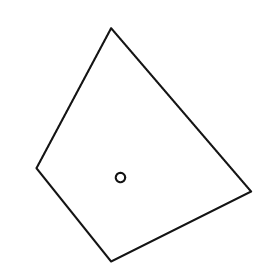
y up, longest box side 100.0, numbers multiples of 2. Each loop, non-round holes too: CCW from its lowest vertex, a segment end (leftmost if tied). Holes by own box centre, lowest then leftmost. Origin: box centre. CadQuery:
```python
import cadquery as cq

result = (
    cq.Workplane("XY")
    .moveTo(-14.0, -50.0)
    .lineTo(46.0, -20.0)
    .lineTo(-14.0, 50.0)
    .lineTo(-46.0, -10.0)
    .close()
    .moveTo(-10.0, -14.0)
    .circle(2.0)
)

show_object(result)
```